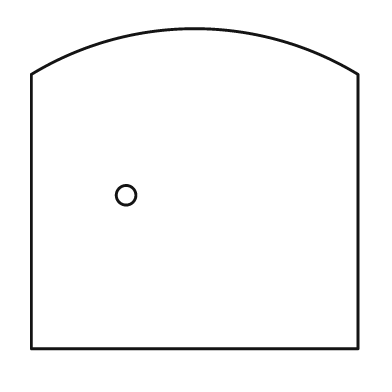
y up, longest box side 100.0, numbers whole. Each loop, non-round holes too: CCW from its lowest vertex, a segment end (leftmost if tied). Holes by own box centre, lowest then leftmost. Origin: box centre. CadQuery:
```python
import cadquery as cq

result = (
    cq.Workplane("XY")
    .moveTo(-50.0, -49.0)
    .lineTo(50.0, -49.0)
    .lineTo(50.0, 35.0)
    .threePointArc((0.0, 49.0), (-50.0, 35.0))
    .close()
    .moveTo(-21.0, -2.0)
    .circle(3.0)
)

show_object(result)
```